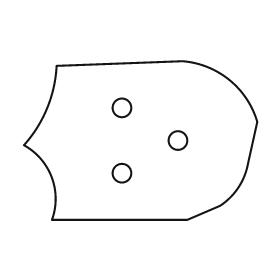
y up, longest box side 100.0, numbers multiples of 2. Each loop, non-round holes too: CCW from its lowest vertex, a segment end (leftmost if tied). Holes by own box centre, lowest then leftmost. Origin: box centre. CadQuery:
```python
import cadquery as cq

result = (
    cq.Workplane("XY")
    .moveTo(-38.0, -34.0)
    .lineTo(20.0, -34.0)
    .lineTo(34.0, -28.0)
    .threePointArc((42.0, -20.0), (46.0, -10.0))
    .lineTo(50.0, 8.0)
    .threePointArc((38.0, 26.0), (18.0, 34.0))
    .lineTo(-36.0, 32.0)
    .threePointArc((-40.0, 14.0), (-50.0, -2.0))
    .threePointArc((-38.0, -16.0), (-38.0, -34.0))
    .close()
    .moveTo(-8.0, -14.0)
    .circle(4.0)
    .moveTo(16.0, 0.0)
    .circle(4.0)
    .moveTo(-8.0, 14.0)
    .circle(4.0)
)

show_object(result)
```